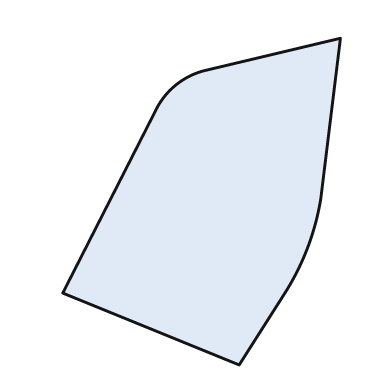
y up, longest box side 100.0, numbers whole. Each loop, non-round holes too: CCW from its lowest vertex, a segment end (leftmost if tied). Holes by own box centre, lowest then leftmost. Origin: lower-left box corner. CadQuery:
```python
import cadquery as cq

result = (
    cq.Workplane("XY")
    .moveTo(54.0, 0.0)
    .lineTo(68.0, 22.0)
    .threePointArc((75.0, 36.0), (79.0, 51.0))
    .lineTo(85.0, 100.0)
    .lineTo(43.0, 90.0)
    .threePointArc((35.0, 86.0), (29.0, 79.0))
    .lineTo(0.0, 22.0)
    .close()
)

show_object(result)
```